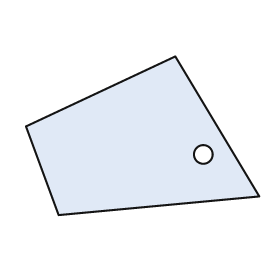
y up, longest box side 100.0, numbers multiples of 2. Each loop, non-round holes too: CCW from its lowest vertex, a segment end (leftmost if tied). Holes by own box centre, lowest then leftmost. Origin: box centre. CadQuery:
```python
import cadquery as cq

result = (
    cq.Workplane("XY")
    .moveTo(-36.0, -34.0)
    .lineTo(50.0, -26.0)
    .lineTo(14.0, 34.0)
    .lineTo(-50.0, 4.0)
    .close()
    .moveTo(26.0, -8.0)
    .circle(4.0)
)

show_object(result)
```